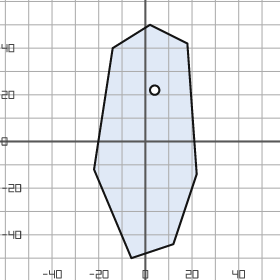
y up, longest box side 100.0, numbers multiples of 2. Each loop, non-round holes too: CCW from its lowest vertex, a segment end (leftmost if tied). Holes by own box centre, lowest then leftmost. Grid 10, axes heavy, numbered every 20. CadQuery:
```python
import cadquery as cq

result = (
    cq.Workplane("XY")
    .moveTo(-6.0, -50.0)
    .lineTo(12.0, -44.0)
    .lineTo(22.0, -14.0)
    .lineTo(18.0, 42.0)
    .lineTo(2.0, 50.0)
    .lineTo(-14.0, 40.0)
    .lineTo(-22.0, -12.0)
    .close()
    .moveTo(4.0, 22.0)
    .circle(2.0)
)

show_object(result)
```